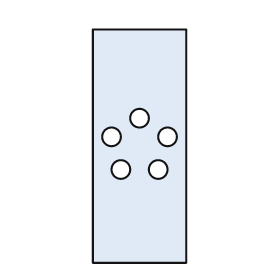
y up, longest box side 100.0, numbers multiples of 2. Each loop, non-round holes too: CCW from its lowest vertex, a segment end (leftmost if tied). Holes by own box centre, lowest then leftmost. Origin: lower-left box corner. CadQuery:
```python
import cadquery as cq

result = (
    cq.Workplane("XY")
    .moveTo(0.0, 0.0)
    .lineTo(40.0, 0.0)
    .lineTo(40.0, 100.0)
    .lineTo(0.0, 100.0)
    .close()
    .moveTo(12.0, 40.0)
    .circle(4.0)
    .moveTo(28.0, 40.0)
    .circle(4.0)
    .moveTo(8.0, 54.0)
    .circle(4.0)
    .moveTo(32.0, 54.0)
    .circle(4.0)
    .moveTo(20.0, 62.0)
    .circle(4.0)
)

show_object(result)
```